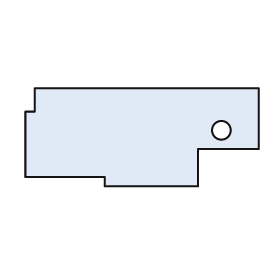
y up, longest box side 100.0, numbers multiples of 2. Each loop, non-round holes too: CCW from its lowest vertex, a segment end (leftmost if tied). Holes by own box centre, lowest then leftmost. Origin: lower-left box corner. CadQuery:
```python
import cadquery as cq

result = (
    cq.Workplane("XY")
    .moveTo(34.0, 0.0)
    .lineTo(74.0, 0.0)
    .lineTo(74.0, 16.0)
    .lineTo(100.0, 16.0)
    .lineTo(100.0, 42.0)
    .lineTo(4.0, 42.0)
    .lineTo(4.0, 32.0)
    .lineTo(0.0, 32.0)
    .lineTo(0.0, 4.0)
    .lineTo(34.0, 4.0)
    .close()
    .moveTo(84.0, 24.0)
    .circle(4.0)
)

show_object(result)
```